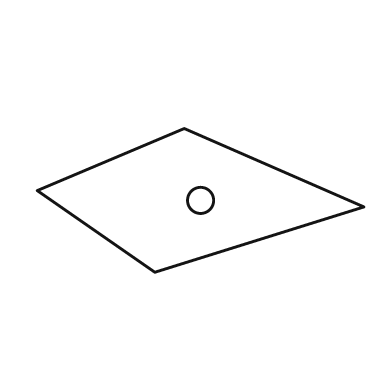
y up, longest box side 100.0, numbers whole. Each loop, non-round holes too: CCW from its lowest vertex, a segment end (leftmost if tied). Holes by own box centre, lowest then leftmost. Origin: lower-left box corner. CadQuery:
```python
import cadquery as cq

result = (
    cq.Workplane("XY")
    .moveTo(36.0, 0.0)
    .lineTo(100.0, 20.0)
    .lineTo(45.0, 44.0)
    .lineTo(0.0, 25.0)
    .close()
    .moveTo(50.0, 22.0)
    .circle(4.0)
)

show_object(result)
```